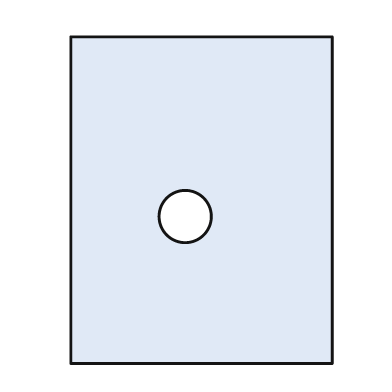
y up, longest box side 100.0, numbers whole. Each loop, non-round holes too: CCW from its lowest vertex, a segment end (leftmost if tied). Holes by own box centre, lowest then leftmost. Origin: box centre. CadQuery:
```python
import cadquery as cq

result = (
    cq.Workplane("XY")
    .moveTo(-40.0, -50.0)
    .lineTo(40.0, -50.0)
    .lineTo(40.0, 50.0)
    .lineTo(-40.0, 50.0)
    .close()
    .moveTo(-5.0, -5.0)
    .circle(8.0)
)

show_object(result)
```